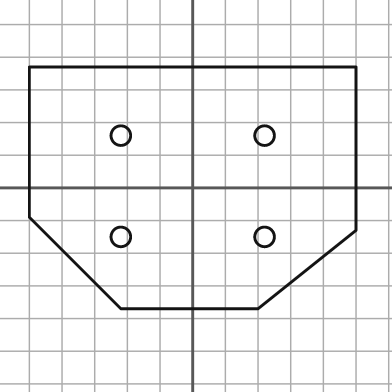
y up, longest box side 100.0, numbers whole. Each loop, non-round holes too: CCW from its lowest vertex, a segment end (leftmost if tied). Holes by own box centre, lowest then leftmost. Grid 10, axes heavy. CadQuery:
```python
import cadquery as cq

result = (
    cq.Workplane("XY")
    .moveTo(-22.0, -37.0)
    .lineTo(20.0, -37.0)
    .lineTo(50.0, -13.0)
    .lineTo(50.0, 37.0)
    .lineTo(-50.0, 37.0)
    .lineTo(-50.0, -9.0)
    .close()
    .moveTo(-22.0, -15.0)
    .circle(3.0)
    .moveTo(22.0, -15.0)
    .circle(3.0)
    .moveTo(-22.0, 16.0)
    .circle(3.0)
    .moveTo(22.0, 16.0)
    .circle(3.0)
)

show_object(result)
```